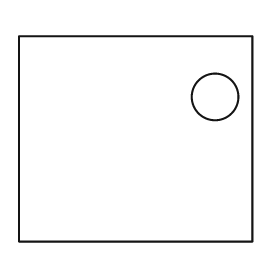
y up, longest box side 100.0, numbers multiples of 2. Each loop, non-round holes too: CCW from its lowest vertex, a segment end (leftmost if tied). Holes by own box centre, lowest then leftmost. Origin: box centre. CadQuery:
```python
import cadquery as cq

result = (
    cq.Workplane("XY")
    .moveTo(-50.0, -44.0)
    .lineTo(50.0, -44.0)
    .lineTo(50.0, 44.0)
    .lineTo(-50.0, 44.0)
    .close()
    .moveTo(34.0, 18.0)
    .circle(10.0)
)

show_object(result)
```